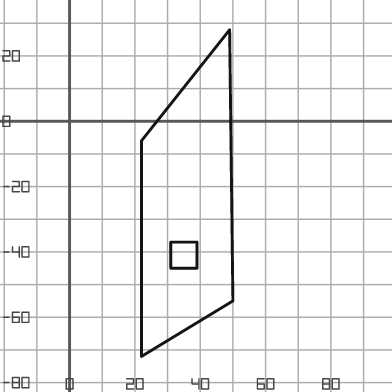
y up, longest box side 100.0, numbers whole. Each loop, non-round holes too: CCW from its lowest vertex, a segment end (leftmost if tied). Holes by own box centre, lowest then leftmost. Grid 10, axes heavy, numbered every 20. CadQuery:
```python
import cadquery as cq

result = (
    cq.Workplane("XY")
    .moveTo(22.0, -72.0)
    .lineTo(50.0, -55.0)
    .lineTo(49.0, 28.0)
    .lineTo(22.0, -6.0)
    .close()
    .moveTo(31.0, -45.0)
    .lineTo(39.0, -45.0)
    .lineTo(39.0, -37.0)
    .lineTo(31.0, -37.0)
    .close()
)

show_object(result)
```